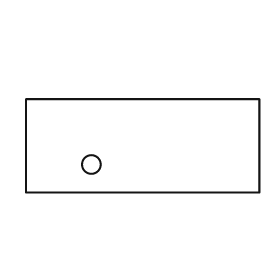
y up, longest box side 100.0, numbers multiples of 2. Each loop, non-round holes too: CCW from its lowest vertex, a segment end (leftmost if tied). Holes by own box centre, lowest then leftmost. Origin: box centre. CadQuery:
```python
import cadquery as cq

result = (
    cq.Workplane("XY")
    .moveTo(-50.0, -20.0)
    .lineTo(50.0, -20.0)
    .lineTo(50.0, 20.0)
    .lineTo(-50.0, 20.0)
    .close()
    .moveTo(-22.0, -8.0)
    .circle(4.0)
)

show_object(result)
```